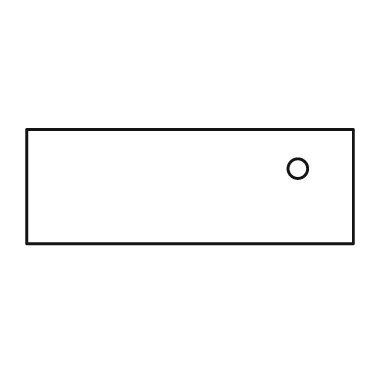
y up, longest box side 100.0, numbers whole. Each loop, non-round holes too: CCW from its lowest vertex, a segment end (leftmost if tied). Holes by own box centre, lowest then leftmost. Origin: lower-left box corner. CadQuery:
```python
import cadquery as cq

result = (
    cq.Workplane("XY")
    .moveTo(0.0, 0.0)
    .lineTo(100.0, 0.0)
    .lineTo(100.0, 35.0)
    .lineTo(0.0, 35.0)
    .close()
    .moveTo(83.0, 23.0)
    .circle(3.0)
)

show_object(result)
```